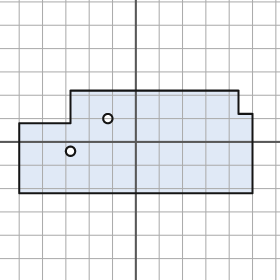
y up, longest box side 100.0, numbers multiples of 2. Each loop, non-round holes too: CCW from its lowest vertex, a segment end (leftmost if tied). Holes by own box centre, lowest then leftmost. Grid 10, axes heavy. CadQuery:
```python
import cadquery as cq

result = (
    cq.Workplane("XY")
    .moveTo(-50.0, -22.0)
    .lineTo(50.0, -22.0)
    .lineTo(50.0, 12.0)
    .lineTo(44.0, 12.0)
    .lineTo(44.0, 22.0)
    .lineTo(-28.0, 22.0)
    .lineTo(-28.0, 8.0)
    .lineTo(-50.0, 8.0)
    .close()
    .moveTo(-28.0, -4.0)
    .circle(2.0)
    .moveTo(-12.0, 10.0)
    .circle(2.0)
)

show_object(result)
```